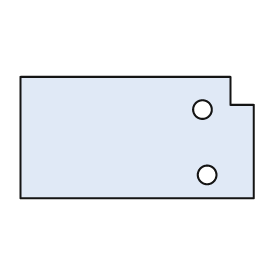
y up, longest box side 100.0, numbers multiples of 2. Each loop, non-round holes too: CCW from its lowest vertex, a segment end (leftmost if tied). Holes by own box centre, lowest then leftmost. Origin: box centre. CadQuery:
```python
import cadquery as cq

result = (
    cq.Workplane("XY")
    .moveTo(-50.0, -26.0)
    .lineTo(50.0, -26.0)
    .lineTo(50.0, 14.0)
    .lineTo(40.0, 14.0)
    .lineTo(40.0, 26.0)
    .lineTo(-50.0, 26.0)
    .close()
    .moveTo(30.0, -16.0)
    .circle(4.0)
    .moveTo(28.0, 12.0)
    .circle(4.0)
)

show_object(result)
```